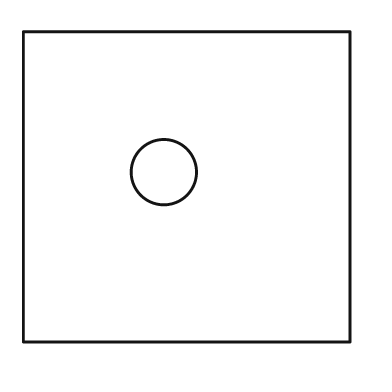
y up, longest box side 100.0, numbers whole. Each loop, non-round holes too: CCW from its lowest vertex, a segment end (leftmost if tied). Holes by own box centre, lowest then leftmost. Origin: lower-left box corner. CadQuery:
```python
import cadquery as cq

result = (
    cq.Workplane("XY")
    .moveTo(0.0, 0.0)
    .lineTo(100.0, 0.0)
    .lineTo(100.0, 95.0)
    .lineTo(0.0, 95.0)
    .close()
    .moveTo(43.0, 52.0)
    .circle(10.0)
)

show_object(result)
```